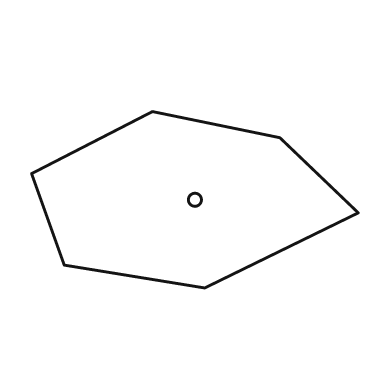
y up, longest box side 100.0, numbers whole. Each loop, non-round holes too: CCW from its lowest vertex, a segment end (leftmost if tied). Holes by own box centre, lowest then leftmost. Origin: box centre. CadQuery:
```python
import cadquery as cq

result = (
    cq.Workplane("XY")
    .moveTo(3.0, -27.0)
    .lineTo(50.0, -4.0)
    .lineTo(26.0, 19.0)
    .lineTo(-13.0, 27.0)
    .lineTo(-50.0, 8.0)
    .lineTo(-40.0, -20.0)
    .close()
    .moveTo(0.0, 0.0)
    .circle(2.0)
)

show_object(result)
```